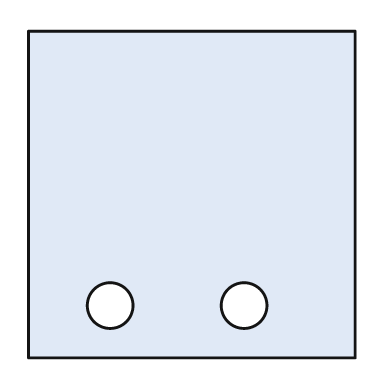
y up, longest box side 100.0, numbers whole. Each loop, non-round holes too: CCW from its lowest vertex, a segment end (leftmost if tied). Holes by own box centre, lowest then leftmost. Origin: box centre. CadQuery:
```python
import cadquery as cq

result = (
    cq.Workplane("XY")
    .moveTo(-50.0, -50.0)
    .lineTo(50.0, -50.0)
    .lineTo(50.0, 50.0)
    .lineTo(-50.0, 50.0)
    .close()
    .moveTo(-25.0, -34.0)
    .circle(7.0)
    .moveTo(16.0, -34.0)
    .circle(7.0)
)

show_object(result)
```